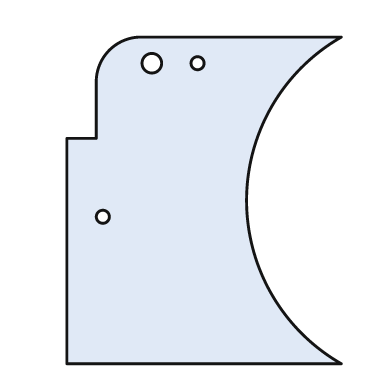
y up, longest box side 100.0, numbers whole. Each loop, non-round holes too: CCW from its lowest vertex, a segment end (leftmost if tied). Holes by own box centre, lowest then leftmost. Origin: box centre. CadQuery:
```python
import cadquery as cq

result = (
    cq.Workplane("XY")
    .moveTo(-42.0, -50.0)
    .lineTo(42.0, -50.0)
    .threePointArc((13.0, 0.0), (42.0, 50.0))
    .lineTo(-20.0, 50.0)
    .threePointArc((-29.0, 46.0), (-33.0, 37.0))
    .lineTo(-33.0, 19.0)
    .lineTo(-42.0, 19.0)
    .close()
    .moveTo(-31.0, -5.0)
    .circle(2.0)
    .moveTo(-16.0, 42.0)
    .circle(3.0)
    .moveTo(-2.0, 42.0)
    .circle(2.0)
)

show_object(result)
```